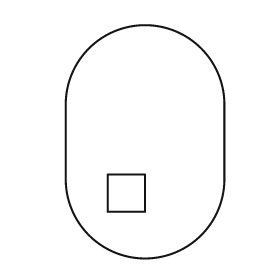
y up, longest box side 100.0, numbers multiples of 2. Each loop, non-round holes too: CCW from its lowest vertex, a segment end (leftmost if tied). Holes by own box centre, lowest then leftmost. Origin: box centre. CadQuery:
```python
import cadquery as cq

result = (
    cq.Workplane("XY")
    .moveTo(-34.0, -16.0)
    .threePointArc((0.0, -50.0), (34.0, -16.0))
    .lineTo(34.0, 16.0)
    .threePointArc((0.0, 50.0), (-34.0, 16.0))
    .close()
    .moveTo(-16.0, -30.0)
    .lineTo(0.0, -30.0)
    .lineTo(0.0, -14.0)
    .lineTo(-16.0, -14.0)
    .close()
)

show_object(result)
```